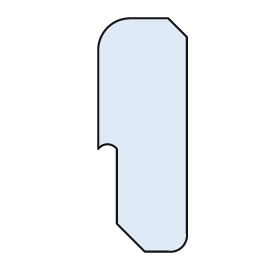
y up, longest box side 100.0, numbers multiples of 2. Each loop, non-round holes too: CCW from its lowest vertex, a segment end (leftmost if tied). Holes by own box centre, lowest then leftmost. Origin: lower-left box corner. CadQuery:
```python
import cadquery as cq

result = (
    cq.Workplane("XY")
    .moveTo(20.0, 0.0)
    .lineTo(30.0, 0.0)
    .threePointArc((36.0, 2.0), (38.0, 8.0))
    .lineTo(38.0, 92.0)
    .lineTo(30.0, 100.0)
    .lineTo(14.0, 100.0)
    .threePointArc((4.0, 96.0), (0.0, 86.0))
    .lineTo(0.0, 44.0)
    .threePointArc((4.0, 46.0), (8.0, 44.0))
    .lineTo(8.0, 12.0)
    .close()
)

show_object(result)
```